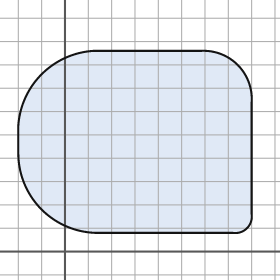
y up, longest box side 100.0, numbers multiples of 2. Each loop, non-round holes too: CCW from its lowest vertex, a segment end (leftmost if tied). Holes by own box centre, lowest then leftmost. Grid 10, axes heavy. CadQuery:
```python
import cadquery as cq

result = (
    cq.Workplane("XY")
    .moveTo(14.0, 8.0)
    .lineTo(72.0, 8.0)
    .threePointArc((78.0, 10.0), (80.0, 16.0))
    .lineTo(80.0, 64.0)
    .threePointArc((74.0, 80.0), (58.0, 86.0))
    .lineTo(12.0, 86.0)
    .threePointArc((-10.0, 76.0), (-20.0, 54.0))
    .lineTo(-20.0, 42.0)
    .threePointArc((-10.0, 18.0), (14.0, 8.0))
    .close()
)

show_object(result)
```